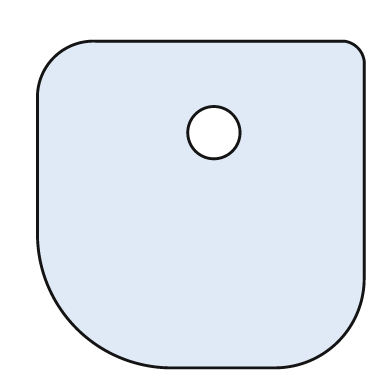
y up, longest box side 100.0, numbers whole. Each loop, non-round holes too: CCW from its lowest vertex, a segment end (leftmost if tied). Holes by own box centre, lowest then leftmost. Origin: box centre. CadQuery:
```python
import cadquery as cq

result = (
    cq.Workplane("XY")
    .moveTo(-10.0, -50.0)
    .lineTo(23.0, -50.0)
    .threePointArc((42.0, -42.0), (50.0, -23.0))
    .lineTo(50.0, 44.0)
    .threePointArc((48.0, 48.0), (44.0, 50.0))
    .lineTo(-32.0, 50.0)
    .threePointArc((-45.0, 45.0), (-50.0, 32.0))
    .lineTo(-50.0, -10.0)
    .threePointArc((-38.0, -38.0), (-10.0, -50.0))
    .close()
    .moveTo(4.0, 22.0)
    .circle(8.0)
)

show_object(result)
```